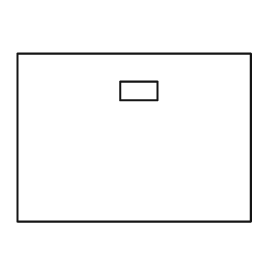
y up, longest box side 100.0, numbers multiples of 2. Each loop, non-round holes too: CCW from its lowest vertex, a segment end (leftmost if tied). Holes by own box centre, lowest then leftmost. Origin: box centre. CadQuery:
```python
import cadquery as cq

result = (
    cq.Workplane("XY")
    .moveTo(-50.0, -36.0)
    .lineTo(50.0, -36.0)
    .lineTo(50.0, 36.0)
    .lineTo(-50.0, 36.0)
    .close()
    .moveTo(-6.0, 16.0)
    .lineTo(10.0, 16.0)
    .lineTo(10.0, 24.0)
    .lineTo(-6.0, 24.0)
    .close()
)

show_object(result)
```